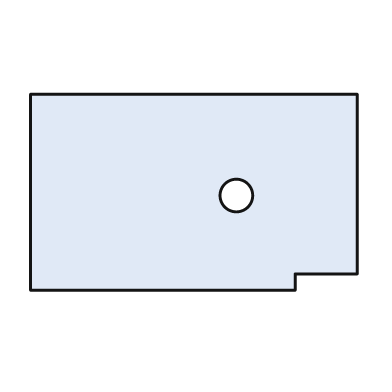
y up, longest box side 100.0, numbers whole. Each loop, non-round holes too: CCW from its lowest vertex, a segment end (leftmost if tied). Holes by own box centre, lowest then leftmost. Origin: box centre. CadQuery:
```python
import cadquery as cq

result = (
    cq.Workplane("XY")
    .moveTo(-50.0, -30.0)
    .lineTo(31.0, -30.0)
    .lineTo(31.0, -25.0)
    .lineTo(50.0, -25.0)
    .lineTo(50.0, 30.0)
    .lineTo(-50.0, 30.0)
    .close()
    .moveTo(13.0, -1.0)
    .circle(5.0)
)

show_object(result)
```